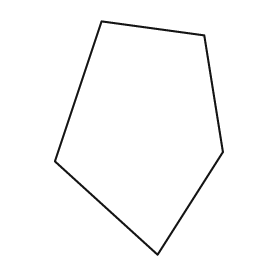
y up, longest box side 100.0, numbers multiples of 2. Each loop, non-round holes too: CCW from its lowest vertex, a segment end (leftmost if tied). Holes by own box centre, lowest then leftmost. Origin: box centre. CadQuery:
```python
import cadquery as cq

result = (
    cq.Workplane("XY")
    .moveTo(8.0, -50.0)
    .lineTo(36.0, -6.0)
    .lineTo(28.0, 44.0)
    .lineTo(-16.0, 50.0)
    .lineTo(-36.0, -10.0)
    .close()
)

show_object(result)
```